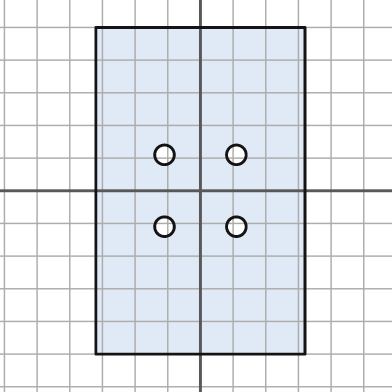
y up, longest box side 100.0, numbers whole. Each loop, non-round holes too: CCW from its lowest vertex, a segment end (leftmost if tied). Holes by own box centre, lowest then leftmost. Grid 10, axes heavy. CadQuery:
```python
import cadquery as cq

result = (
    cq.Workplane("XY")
    .moveTo(-32.0, -50.0)
    .lineTo(32.0, -50.0)
    .lineTo(32.0, 50.0)
    .lineTo(-32.0, 50.0)
    .close()
    .moveTo(-11.0, -11.0)
    .circle(3.0)
    .moveTo(11.0, -11.0)
    .circle(3.0)
    .moveTo(-11.0, 11.0)
    .circle(3.0)
    .moveTo(11.0, 11.0)
    .circle(3.0)
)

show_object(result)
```